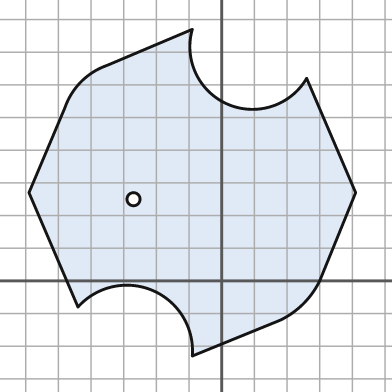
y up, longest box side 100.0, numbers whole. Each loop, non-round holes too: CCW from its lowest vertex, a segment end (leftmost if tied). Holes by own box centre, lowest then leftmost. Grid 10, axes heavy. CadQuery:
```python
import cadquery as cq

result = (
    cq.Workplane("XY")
    .moveTo(-9.0, -23.0)
    .lineTo(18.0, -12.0)
    .threePointArc((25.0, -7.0), (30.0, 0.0))
    .lineTo(41.0, 27.0)
    .lineTo(26.0, 62.0)
    .threePointArc((2.0, 54.0), (-9.0, 77.0))
    .lineTo(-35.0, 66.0)
    .threePointArc((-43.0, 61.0), (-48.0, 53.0))
    .lineTo(-59.0, 27.0)
    .lineTo(-44.0, -8.0)
    .threePointArc((-21.0, -3.0), (-9.0, -23.0))
    .close()
    .moveTo(-27.0, 25.0)
    .circle(2.0)
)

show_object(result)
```